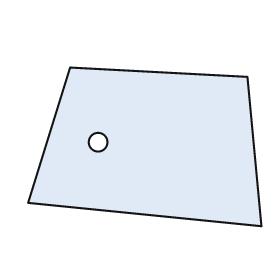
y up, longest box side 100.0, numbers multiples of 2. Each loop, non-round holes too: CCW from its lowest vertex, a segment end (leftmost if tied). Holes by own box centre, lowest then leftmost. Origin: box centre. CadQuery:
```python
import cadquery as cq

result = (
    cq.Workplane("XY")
    .moveTo(50.0, -34.0)
    .lineTo(44.0, 30.0)
    .lineTo(-32.0, 34.0)
    .lineTo(-50.0, -24.0)
    .close()
    .moveTo(-20.0, 2.0)
    .circle(4.0)
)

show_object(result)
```